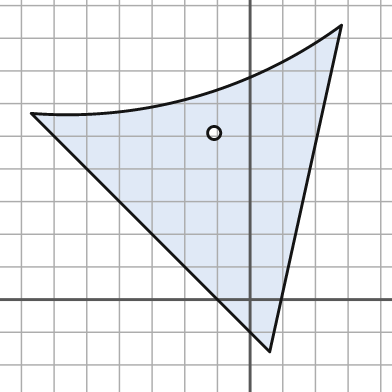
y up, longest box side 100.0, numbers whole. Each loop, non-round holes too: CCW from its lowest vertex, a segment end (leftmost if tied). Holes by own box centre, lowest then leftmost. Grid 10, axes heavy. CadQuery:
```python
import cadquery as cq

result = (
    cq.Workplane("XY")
    .moveTo(6.0, -16.0)
    .lineTo(28.0, 84.0)
    .threePointArc((-17.0, 62.0), (-67.0, 57.0))
    .close()
    .moveTo(-11.0, 51.0)
    .circle(2.0)
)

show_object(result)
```